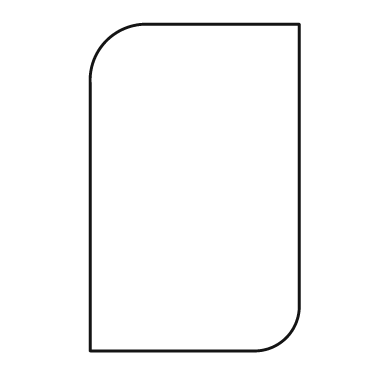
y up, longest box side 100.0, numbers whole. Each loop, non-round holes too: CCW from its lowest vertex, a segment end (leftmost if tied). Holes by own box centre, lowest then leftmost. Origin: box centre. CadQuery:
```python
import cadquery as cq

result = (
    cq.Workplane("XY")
    .moveTo(-32.0, -50.0)
    .lineTo(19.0, -50.0)
    .threePointArc((28.0, -46.0), (32.0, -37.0))
    .lineTo(32.0, 50.0)
    .lineTo(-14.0, 50.0)
    .threePointArc((-27.0, 45.0), (-32.0, 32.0))
    .close()
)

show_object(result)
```